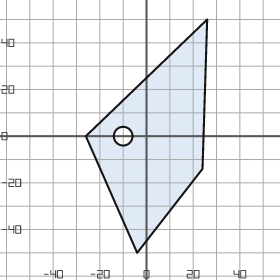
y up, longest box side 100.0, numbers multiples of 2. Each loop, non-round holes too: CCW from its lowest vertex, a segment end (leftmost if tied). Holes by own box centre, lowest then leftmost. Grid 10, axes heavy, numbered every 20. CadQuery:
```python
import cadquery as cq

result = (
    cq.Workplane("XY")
    .moveTo(-4.0, -50.0)
    .lineTo(24.0, -14.0)
    .lineTo(26.0, 50.0)
    .lineTo(-26.0, 0.0)
    .close()
    .moveTo(-10.0, 0.0)
    .circle(4.0)
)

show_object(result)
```